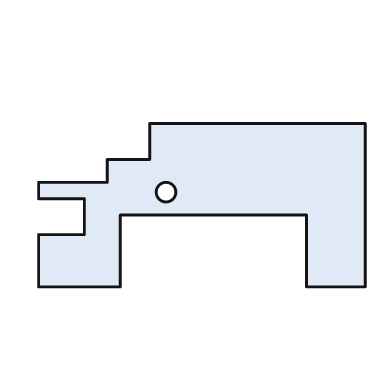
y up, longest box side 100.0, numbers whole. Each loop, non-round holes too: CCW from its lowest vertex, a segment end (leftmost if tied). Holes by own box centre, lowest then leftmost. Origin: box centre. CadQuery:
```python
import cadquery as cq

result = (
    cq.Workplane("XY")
    .moveTo(-50.0, -25.0)
    .lineTo(-25.0, -25.0)
    .lineTo(-25.0, -3.0)
    .lineTo(32.0, -3.0)
    .lineTo(32.0, -25.0)
    .lineTo(50.0, -25.0)
    .lineTo(50.0, 25.0)
    .lineTo(-16.0, 25.0)
    .lineTo(-16.0, 14.0)
    .lineTo(-29.0, 14.0)
    .lineTo(-29.0, 7.0)
    .lineTo(-50.0, 7.0)
    .lineTo(-50.0, 2.0)
    .lineTo(-36.0, 2.0)
    .lineTo(-36.0, -9.0)
    .lineTo(-50.0, -9.0)
    .close()
    .moveTo(-11.0, 4.0)
    .circle(3.0)
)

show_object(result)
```